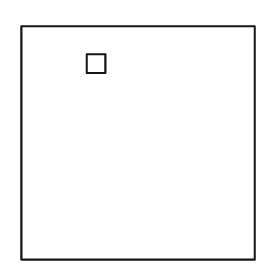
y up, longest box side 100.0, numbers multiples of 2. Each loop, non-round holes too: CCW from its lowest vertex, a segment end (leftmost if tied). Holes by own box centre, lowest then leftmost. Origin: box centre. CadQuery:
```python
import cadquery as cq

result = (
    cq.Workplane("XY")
    .moveTo(-50.0, -50.0)
    .lineTo(50.0, -50.0)
    .lineTo(50.0, 50.0)
    .lineTo(-50.0, 50.0)
    .close()
    .moveTo(-22.0, 30.0)
    .lineTo(-14.0, 30.0)
    .lineTo(-14.0, 38.0)
    .lineTo(-22.0, 38.0)
    .close()
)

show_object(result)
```